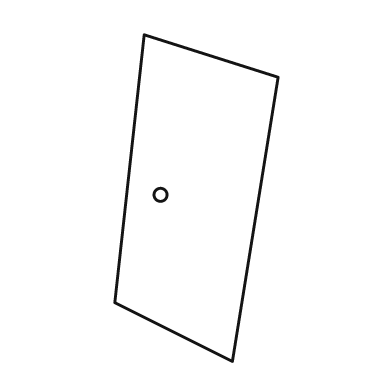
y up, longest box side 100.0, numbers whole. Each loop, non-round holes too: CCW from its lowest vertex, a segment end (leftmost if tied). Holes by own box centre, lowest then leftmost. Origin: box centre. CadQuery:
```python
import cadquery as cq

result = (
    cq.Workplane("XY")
    .moveTo(11.0, -50.0)
    .lineTo(25.0, 37.0)
    .lineTo(-16.0, 50.0)
    .lineTo(-25.0, -32.0)
    .close()
    .moveTo(-11.0, 1.0)
    .circle(2.0)
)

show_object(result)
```